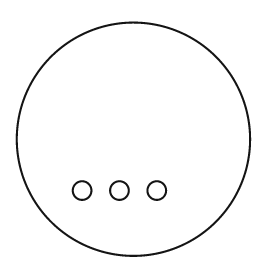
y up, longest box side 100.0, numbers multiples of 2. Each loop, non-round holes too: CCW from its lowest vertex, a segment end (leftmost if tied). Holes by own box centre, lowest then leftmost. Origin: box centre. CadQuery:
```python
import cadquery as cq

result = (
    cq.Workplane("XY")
    .moveTo(0.0, 0.0)
    .circle(50.0)
    .moveTo(-22.0, -22.0)
    .circle(4.0)
    .moveTo(-6.0, -22.0)
    .circle(4.0)
    .moveTo(10.0, -22.0)
    .circle(4.0)
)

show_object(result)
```